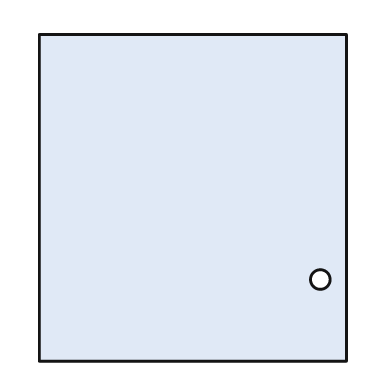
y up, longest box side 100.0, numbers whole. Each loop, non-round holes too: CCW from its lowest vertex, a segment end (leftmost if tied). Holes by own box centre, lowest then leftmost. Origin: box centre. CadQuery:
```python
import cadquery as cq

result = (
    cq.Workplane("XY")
    .moveTo(-47.0, -50.0)
    .lineTo(47.0, -50.0)
    .lineTo(47.0, 50.0)
    .lineTo(-47.0, 50.0)
    .close()
    .moveTo(39.0, -25.0)
    .circle(3.0)
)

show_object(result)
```